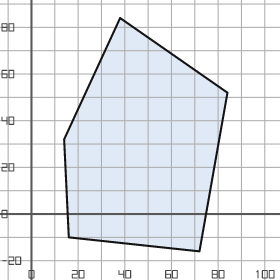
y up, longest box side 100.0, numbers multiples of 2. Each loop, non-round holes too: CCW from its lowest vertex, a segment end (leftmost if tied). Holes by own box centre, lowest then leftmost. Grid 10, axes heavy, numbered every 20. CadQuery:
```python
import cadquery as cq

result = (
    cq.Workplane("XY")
    .moveTo(72.0, -16.0)
    .lineTo(84.0, 52.0)
    .lineTo(38.0, 84.0)
    .lineTo(14.0, 32.0)
    .lineTo(16.0, -10.0)
    .close()
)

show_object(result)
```